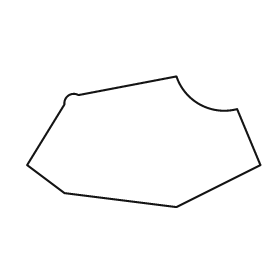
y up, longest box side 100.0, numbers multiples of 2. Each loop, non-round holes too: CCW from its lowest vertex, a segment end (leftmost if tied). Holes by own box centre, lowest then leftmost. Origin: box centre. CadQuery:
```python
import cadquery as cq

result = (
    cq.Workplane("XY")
    .moveTo(14.0, -28.0)
    .lineTo(50.0, -10.0)
    .lineTo(40.0, 14.0)
    .threePointArc((24.0, 16.0), (14.0, 28.0))
    .lineTo(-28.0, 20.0)
    .threePointArc((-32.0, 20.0), (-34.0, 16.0))
    .lineTo(-50.0, -10.0)
    .lineTo(-34.0, -22.0)
    .close()
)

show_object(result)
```